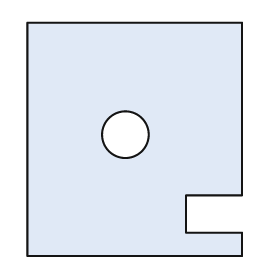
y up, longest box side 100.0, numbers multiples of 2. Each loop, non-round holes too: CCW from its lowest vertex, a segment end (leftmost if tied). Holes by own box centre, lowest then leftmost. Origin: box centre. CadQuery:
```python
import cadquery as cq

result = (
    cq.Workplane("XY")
    .moveTo(-46.0, -50.0)
    .lineTo(46.0, -50.0)
    .lineTo(46.0, -40.0)
    .lineTo(22.0, -40.0)
    .lineTo(22.0, -24.0)
    .lineTo(46.0, -24.0)
    .lineTo(46.0, 50.0)
    .lineTo(-46.0, 50.0)
    .close()
    .moveTo(-4.0, 2.0)
    .circle(10.0)
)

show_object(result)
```